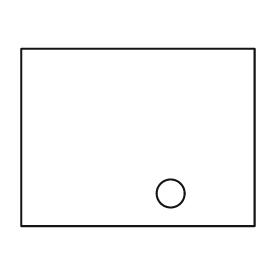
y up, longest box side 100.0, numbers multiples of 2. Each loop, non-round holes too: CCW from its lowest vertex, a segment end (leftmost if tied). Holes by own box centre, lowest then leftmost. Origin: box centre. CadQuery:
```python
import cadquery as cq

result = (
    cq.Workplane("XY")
    .moveTo(-50.0, -38.0)
    .lineTo(50.0, -38.0)
    .lineTo(50.0, 38.0)
    .lineTo(-50.0, 38.0)
    .close()
    .moveTo(14.0, -24.0)
    .circle(6.0)
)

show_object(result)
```